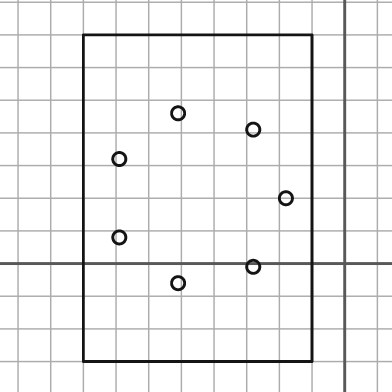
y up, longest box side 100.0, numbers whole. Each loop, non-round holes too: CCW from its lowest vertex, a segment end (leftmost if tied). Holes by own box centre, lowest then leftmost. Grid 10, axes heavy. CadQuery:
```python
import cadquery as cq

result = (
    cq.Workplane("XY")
    .moveTo(-80.0, -30.0)
    .lineTo(-10.0, -30.0)
    .lineTo(-10.0, 70.0)
    .lineTo(-80.0, 70.0)
    .close()
    .moveTo(-51.0, -6.0)
    .circle(2.0)
    .moveTo(-28.0, -1.0)
    .circle(2.0)
    .moveTo(-69.0, 8.0)
    .circle(2.0)
    .moveTo(-18.0, 20.0)
    .circle(2.0)
    .moveTo(-69.0, 32.0)
    .circle(2.0)
    .moveTo(-28.0, 41.0)
    .circle(2.0)
    .moveTo(-51.0, 46.0)
    .circle(2.0)
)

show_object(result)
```